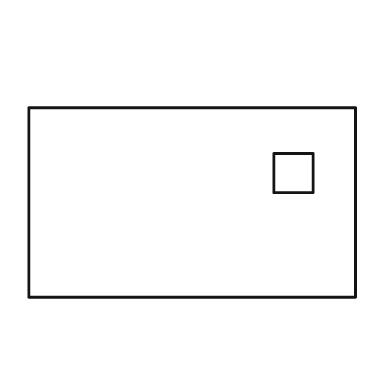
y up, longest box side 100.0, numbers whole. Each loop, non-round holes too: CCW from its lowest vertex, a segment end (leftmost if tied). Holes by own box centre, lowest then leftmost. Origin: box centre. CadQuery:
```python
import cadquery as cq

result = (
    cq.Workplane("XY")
    .moveTo(-50.0, -29.0)
    .lineTo(50.0, -29.0)
    .lineTo(50.0, 29.0)
    .lineTo(-50.0, 29.0)
    .close()
    .moveTo(25.0, 3.0)
    .lineTo(37.0, 3.0)
    .lineTo(37.0, 15.0)
    .lineTo(25.0, 15.0)
    .close()
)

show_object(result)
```